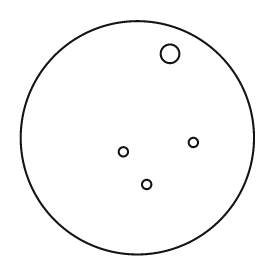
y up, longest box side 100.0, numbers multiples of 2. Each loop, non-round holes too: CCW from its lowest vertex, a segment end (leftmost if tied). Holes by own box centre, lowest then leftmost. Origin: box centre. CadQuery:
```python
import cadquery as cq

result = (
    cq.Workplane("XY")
    .moveTo(0.0, 0.0)
    .circle(50.0)
    .moveTo(4.0, -20.0)
    .circle(2.0)
    .moveTo(-6.0, -6.0)
    .circle(2.0)
    .moveTo(24.0, -2.0)
    .circle(2.0)
    .moveTo(14.0, 36.0)
    .circle(4.0)
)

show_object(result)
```